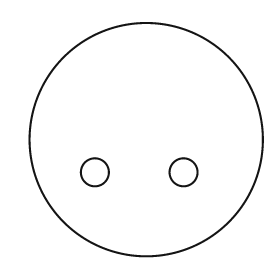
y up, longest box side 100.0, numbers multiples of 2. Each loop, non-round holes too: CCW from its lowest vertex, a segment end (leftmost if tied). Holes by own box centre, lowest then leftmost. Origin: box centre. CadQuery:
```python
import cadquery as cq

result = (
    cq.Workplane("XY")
    .moveTo(0.0, 0.0)
    .circle(50.0)
    .moveTo(-22.0, -14.0)
    .circle(6.0)
    .moveTo(16.0, -14.0)
    .circle(6.0)
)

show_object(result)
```